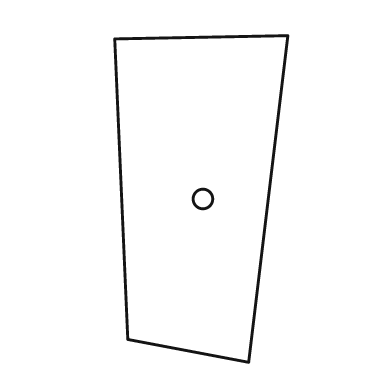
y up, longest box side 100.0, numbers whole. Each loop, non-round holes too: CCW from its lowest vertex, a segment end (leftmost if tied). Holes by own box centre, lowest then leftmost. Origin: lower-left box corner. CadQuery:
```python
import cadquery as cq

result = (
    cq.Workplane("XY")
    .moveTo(41.0, 0.0)
    .lineTo(53.0, 100.0)
    .lineTo(0.0, 99.0)
    .lineTo(4.0, 7.0)
    .close()
    .moveTo(27.0, 50.0)
    .circle(3.0)
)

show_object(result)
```